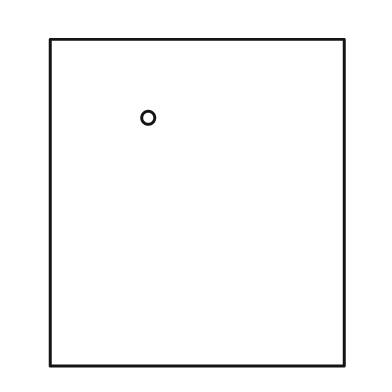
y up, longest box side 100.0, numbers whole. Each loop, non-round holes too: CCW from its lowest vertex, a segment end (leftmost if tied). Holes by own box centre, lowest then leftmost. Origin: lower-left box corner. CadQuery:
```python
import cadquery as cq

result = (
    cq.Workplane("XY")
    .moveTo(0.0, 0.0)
    .lineTo(90.0, 0.0)
    .lineTo(90.0, 100.0)
    .lineTo(0.0, 100.0)
    .close()
    .moveTo(30.0, 76.0)
    .circle(2.0)
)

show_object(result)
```